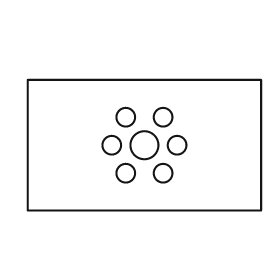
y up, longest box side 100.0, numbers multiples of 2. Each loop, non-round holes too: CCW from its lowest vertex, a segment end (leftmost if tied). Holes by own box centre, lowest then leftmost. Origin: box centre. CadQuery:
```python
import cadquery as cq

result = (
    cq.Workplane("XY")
    .moveTo(-50.0, -28.0)
    .lineTo(50.0, -28.0)
    .lineTo(50.0, 28.0)
    .lineTo(-50.0, 28.0)
    .close()
    .moveTo(-8.0, -12.0)
    .circle(4.0)
    .moveTo(8.0, -12.0)
    .circle(4.0)
    .moveTo(-14.0, 0.0)
    .circle(4.0)
    .moveTo(0.0, 0.0)
    .circle(6.0)
    .moveTo(14.0, 0.0)
    .circle(4.0)
    .moveTo(-8.0, 12.0)
    .circle(4.0)
    .moveTo(8.0, 12.0)
    .circle(4.0)
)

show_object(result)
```